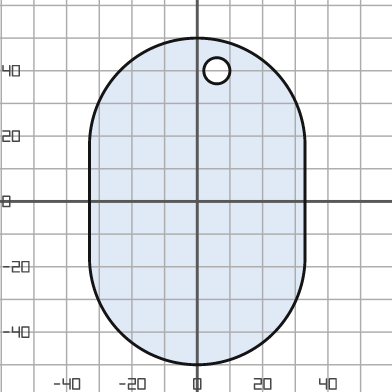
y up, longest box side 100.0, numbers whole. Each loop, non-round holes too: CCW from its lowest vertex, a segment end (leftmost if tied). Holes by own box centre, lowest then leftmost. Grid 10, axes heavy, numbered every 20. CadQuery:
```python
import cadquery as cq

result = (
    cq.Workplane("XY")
    .moveTo(-33.0, -17.0)
    .threePointArc((0.0, -50.0), (33.0, -17.0))
    .lineTo(33.0, 17.0)
    .threePointArc((0.0, 50.0), (-33.0, 17.0))
    .close()
    .moveTo(6.0, 40.0)
    .circle(4.0)
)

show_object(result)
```